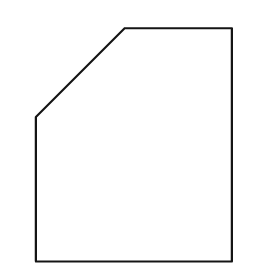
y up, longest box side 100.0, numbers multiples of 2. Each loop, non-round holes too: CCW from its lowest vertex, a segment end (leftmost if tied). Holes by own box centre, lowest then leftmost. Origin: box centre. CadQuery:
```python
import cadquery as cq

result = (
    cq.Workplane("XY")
    .moveTo(-42.0, -50.0)
    .lineTo(42.0, -50.0)
    .lineTo(42.0, 50.0)
    .lineTo(-4.0, 50.0)
    .lineTo(-42.0, 12.0)
    .close()
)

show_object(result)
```